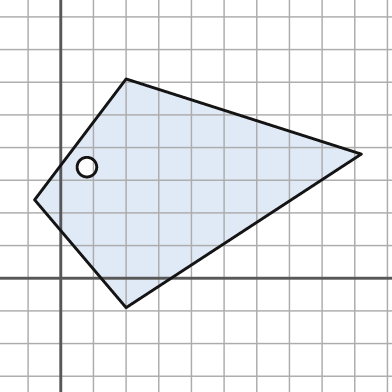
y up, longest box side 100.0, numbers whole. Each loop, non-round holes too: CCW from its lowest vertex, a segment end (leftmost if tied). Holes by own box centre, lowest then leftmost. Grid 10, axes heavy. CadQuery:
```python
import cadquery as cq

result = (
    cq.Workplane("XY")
    .moveTo(20.0, -9.0)
    .lineTo(92.0, 38.0)
    .lineTo(20.0, 61.0)
    .lineTo(-8.0, 24.0)
    .close()
    .moveTo(8.0, 34.0)
    .circle(3.0)
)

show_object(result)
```